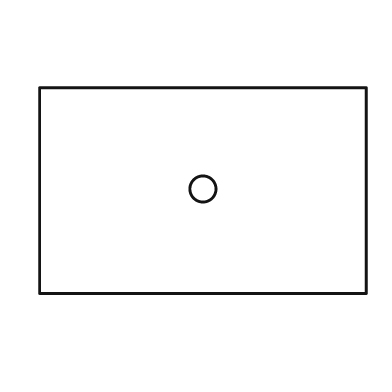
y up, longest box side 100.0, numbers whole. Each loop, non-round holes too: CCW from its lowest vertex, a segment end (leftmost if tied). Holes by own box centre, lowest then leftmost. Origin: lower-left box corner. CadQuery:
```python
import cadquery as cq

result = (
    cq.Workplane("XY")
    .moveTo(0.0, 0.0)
    .lineTo(100.0, 0.0)
    .lineTo(100.0, 63.0)
    .lineTo(0.0, 63.0)
    .close()
    .moveTo(50.0, 32.0)
    .circle(4.0)
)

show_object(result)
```